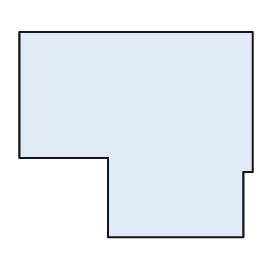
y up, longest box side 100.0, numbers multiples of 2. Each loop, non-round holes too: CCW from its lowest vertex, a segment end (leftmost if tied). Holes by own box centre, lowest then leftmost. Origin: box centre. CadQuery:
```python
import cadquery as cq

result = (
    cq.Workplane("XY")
    .moveTo(-12.0, -44.0)
    .lineTo(46.0, -44.0)
    .lineTo(46.0, -16.0)
    .lineTo(50.0, -16.0)
    .lineTo(50.0, 44.0)
    .lineTo(-50.0, 44.0)
    .lineTo(-50.0, -10.0)
    .lineTo(-12.0, -10.0)
    .close()
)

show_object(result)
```